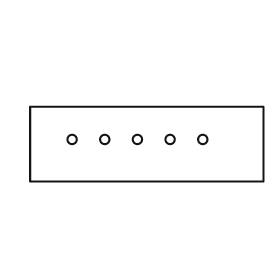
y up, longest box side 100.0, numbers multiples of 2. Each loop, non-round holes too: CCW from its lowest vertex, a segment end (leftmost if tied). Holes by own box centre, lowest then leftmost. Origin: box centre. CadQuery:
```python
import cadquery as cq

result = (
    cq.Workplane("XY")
    .moveTo(-50.0, -16.0)
    .lineTo(50.0, -16.0)
    .lineTo(50.0, 16.0)
    .lineTo(-50.0, 16.0)
    .close()
    .moveTo(-32.0, 2.0)
    .circle(2.0)
    .moveTo(-18.0, 2.0)
    .circle(2.0)
    .moveTo(-4.0, 2.0)
    .circle(2.0)
    .moveTo(10.0, 2.0)
    .circle(2.0)
    .moveTo(24.0, 2.0)
    .circle(2.0)
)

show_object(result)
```